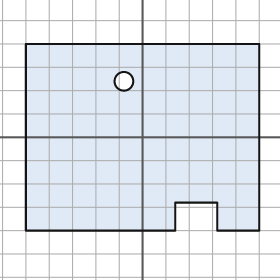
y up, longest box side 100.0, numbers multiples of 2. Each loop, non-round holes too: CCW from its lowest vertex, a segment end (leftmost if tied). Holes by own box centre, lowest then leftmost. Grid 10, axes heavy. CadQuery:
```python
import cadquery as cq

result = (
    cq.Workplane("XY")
    .moveTo(-50.0, -40.0)
    .lineTo(14.0, -40.0)
    .lineTo(14.0, -28.0)
    .lineTo(32.0, -28.0)
    .lineTo(32.0, -40.0)
    .lineTo(50.0, -40.0)
    .lineTo(50.0, 40.0)
    .lineTo(-50.0, 40.0)
    .close()
    .moveTo(-8.0, 24.0)
    .circle(4.0)
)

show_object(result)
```